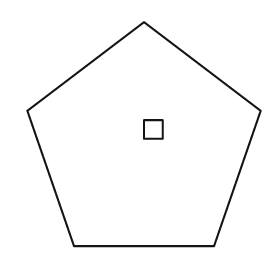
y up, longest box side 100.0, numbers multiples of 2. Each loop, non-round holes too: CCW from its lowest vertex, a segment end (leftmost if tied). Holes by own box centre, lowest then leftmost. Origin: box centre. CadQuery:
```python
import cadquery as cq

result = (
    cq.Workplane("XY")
    .moveTo(-30.0, -48.0)
    .lineTo(30.0, -48.0)
    .lineTo(50.0, 10.0)
    .lineTo(0.0, 48.0)
    .lineTo(-50.0, 10.0)
    .close()
    .moveTo(0.0, -2.0)
    .lineTo(8.0, -2.0)
    .lineTo(8.0, 6.0)
    .lineTo(0.0, 6.0)
    .close()
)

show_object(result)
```